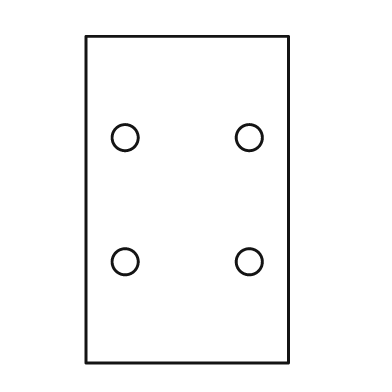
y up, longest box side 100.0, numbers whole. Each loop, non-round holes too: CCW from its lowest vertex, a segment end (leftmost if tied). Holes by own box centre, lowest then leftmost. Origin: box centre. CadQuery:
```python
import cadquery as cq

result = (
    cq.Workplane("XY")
    .moveTo(-31.0, -50.0)
    .lineTo(31.0, -50.0)
    .lineTo(31.0, 50.0)
    .lineTo(-31.0, 50.0)
    .close()
    .moveTo(-19.0, -19.0)
    .circle(4.0)
    .moveTo(19.0, -19.0)
    .circle(4.0)
    .moveTo(-19.0, 19.0)
    .circle(4.0)
    .moveTo(19.0, 19.0)
    .circle(4.0)
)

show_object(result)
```